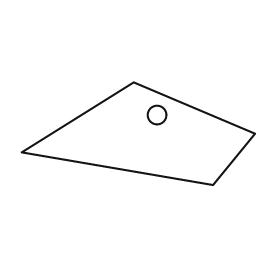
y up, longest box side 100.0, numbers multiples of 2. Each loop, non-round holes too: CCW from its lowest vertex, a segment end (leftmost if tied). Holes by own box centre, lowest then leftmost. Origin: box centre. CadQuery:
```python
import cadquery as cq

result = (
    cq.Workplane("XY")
    .moveTo(32.0, -22.0)
    .lineTo(50.0, 0.0)
    .lineTo(-2.0, 22.0)
    .lineTo(-50.0, -8.0)
    .close()
    .moveTo(8.0, 8.0)
    .circle(4.0)
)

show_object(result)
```